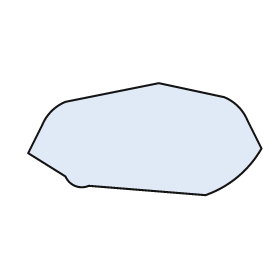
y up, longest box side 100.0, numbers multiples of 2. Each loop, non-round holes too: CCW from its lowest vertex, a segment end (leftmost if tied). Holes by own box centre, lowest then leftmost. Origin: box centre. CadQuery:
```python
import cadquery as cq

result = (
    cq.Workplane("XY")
    .moveTo(26.0, -24.0)
    .threePointArc((40.0, -16.0), (50.0, -4.0))
    .lineTo(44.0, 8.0)
    .threePointArc((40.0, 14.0), (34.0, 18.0))
    .lineTo(6.0, 24.0)
    .lineTo(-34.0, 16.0)
    .threePointArc((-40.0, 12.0), (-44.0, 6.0))
    .lineTo(-50.0, -6.0)
    .lineTo(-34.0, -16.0)
    .threePointArc((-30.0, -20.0), (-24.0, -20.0))
    .close()
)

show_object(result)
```